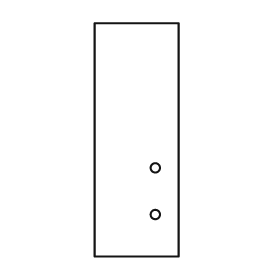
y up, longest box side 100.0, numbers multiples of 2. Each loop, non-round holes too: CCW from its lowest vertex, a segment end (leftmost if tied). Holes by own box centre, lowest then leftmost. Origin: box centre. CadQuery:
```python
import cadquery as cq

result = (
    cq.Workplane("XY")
    .moveTo(-18.0, -50.0)
    .lineTo(18.0, -50.0)
    .lineTo(18.0, 50.0)
    .lineTo(-18.0, 50.0)
    .close()
    .moveTo(8.0, -32.0)
    .circle(2.0)
    .moveTo(8.0, -12.0)
    .circle(2.0)
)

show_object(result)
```